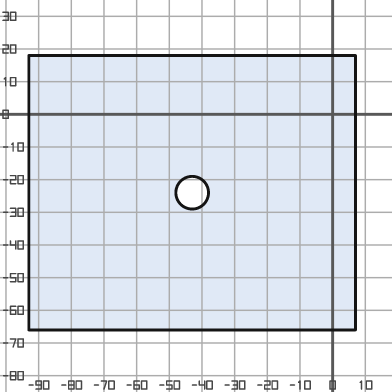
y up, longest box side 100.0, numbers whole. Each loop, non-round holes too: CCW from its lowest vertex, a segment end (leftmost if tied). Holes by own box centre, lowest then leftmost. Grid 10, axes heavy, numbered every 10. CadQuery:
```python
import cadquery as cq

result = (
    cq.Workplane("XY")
    .moveTo(-93.0, -66.0)
    .lineTo(7.0, -66.0)
    .lineTo(7.0, 18.0)
    .lineTo(-93.0, 18.0)
    .close()
    .moveTo(-43.0, -24.0)
    .circle(5.0)
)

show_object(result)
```